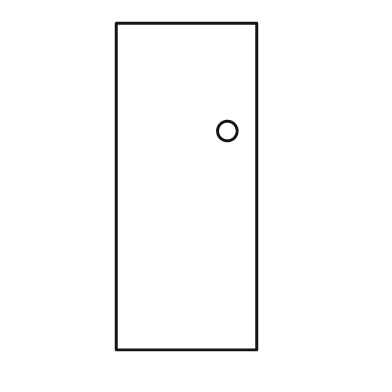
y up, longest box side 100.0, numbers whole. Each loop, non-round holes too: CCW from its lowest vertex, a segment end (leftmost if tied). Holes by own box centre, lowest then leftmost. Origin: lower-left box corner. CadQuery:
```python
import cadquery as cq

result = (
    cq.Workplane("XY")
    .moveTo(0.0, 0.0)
    .lineTo(43.0, 0.0)
    .lineTo(43.0, 100.0)
    .lineTo(0.0, 100.0)
    .close()
    .moveTo(34.0, 67.0)
    .circle(3.0)
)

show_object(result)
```